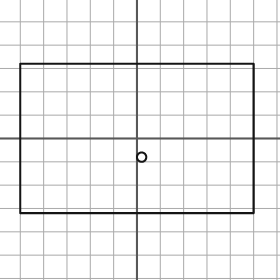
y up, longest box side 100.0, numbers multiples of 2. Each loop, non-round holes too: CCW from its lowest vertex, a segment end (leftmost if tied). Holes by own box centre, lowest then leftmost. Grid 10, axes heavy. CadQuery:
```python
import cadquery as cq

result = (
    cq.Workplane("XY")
    .moveTo(-50.0, -32.0)
    .lineTo(50.0, -32.0)
    .lineTo(50.0, 32.0)
    .lineTo(-50.0, 32.0)
    .close()
    .moveTo(2.0, -8.0)
    .circle(2.0)
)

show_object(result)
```